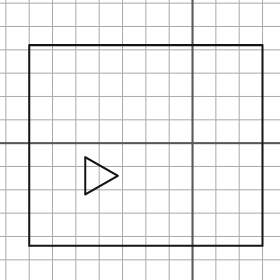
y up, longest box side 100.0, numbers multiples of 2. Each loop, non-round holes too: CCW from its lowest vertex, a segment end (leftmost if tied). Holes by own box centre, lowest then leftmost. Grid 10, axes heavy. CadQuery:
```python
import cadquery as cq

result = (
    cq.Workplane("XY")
    .moveTo(-70.0, -44.0)
    .lineTo(30.0, -44.0)
    .lineTo(30.0, 42.0)
    .lineTo(-70.0, 42.0)
    .close()
    .moveTo(-46.0, -22.0)
    .lineTo(-32.0, -14.0)
    .lineTo(-46.0, -6.0)
    .close()
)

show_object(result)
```